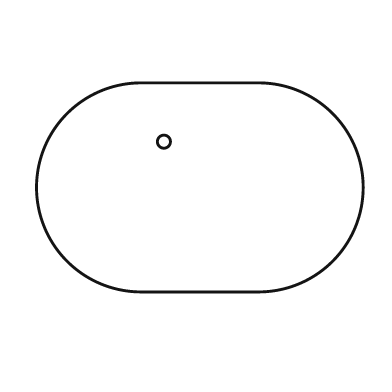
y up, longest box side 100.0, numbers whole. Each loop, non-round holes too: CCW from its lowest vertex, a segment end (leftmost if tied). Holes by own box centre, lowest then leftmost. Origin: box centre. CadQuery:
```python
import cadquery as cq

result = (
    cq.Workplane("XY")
    .moveTo(-18.0, -32.0)
    .lineTo(18.0, -32.0)
    .threePointArc((50.0, 0.0), (18.0, 32.0))
    .lineTo(-18.0, 32.0)
    .threePointArc((-50.0, 0.0), (-18.0, -32.0))
    .close()
    .moveTo(-11.0, 14.0)
    .circle(2.0)
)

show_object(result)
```